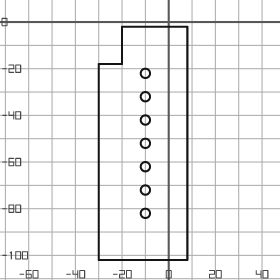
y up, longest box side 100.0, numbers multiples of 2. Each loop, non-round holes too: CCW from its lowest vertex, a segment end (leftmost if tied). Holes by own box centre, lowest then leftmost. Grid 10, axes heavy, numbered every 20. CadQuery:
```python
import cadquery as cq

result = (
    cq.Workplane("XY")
    .moveTo(-30.0, -102.0)
    .lineTo(8.0, -102.0)
    .lineTo(8.0, -2.0)
    .lineTo(-20.0, -2.0)
    .lineTo(-20.0, -18.0)
    .lineTo(-30.0, -18.0)
    .close()
    .moveTo(-10.0, -82.0)
    .circle(2.0)
    .moveTo(-10.0, -72.0)
    .circle(2.0)
    .moveTo(-10.0, -62.0)
    .circle(2.0)
    .moveTo(-10.0, -52.0)
    .circle(2.0)
    .moveTo(-10.0, -42.0)
    .circle(2.0)
    .moveTo(-10.0, -32.0)
    .circle(2.0)
    .moveTo(-10.0, -22.0)
    .circle(2.0)
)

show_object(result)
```